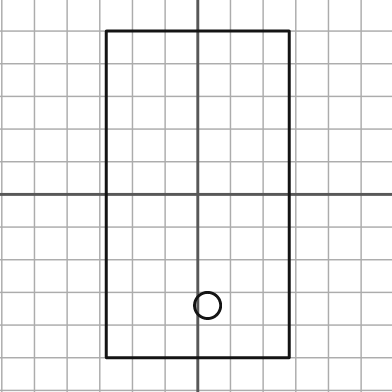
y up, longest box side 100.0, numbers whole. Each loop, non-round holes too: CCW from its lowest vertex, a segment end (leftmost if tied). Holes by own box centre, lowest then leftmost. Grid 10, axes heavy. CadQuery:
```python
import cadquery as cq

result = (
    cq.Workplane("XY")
    .moveTo(-28.0, -50.0)
    .lineTo(28.0, -50.0)
    .lineTo(28.0, 50.0)
    .lineTo(-28.0, 50.0)
    .close()
    .moveTo(3.0, -34.0)
    .circle(4.0)
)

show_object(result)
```